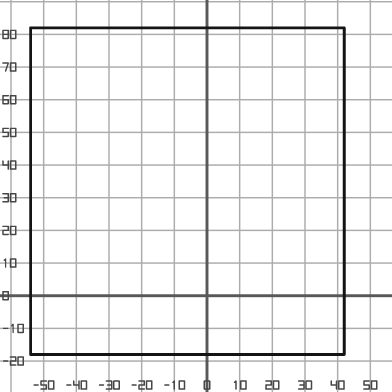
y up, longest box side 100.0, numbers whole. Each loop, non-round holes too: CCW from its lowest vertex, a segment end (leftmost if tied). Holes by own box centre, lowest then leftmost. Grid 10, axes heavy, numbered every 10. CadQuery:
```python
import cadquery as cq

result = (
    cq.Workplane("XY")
    .moveTo(-54.0, -18.0)
    .lineTo(42.0, -18.0)
    .lineTo(42.0, 82.0)
    .lineTo(-54.0, 82.0)
    .close()
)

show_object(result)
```